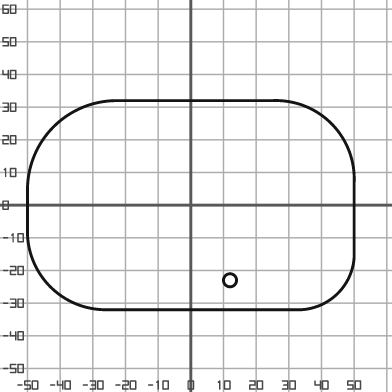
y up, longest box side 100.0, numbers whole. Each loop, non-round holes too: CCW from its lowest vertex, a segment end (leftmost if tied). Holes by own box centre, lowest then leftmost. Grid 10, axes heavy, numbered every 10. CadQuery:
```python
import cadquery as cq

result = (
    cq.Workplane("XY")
    .moveTo(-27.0, -32.0)
    .lineTo(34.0, -32.0)
    .threePointArc((45.0, -27.0), (50.0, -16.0))
    .lineTo(50.0, 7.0)
    .threePointArc((43.0, 25.0), (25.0, 32.0))
    .lineTo(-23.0, 32.0)
    .threePointArc((-42.0, 24.0), (-50.0, 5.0))
    .lineTo(-50.0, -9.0)
    .threePointArc((-43.0, -25.0), (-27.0, -32.0))
    .close()
    .moveTo(12.0, -23.0)
    .circle(2.0)
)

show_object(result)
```